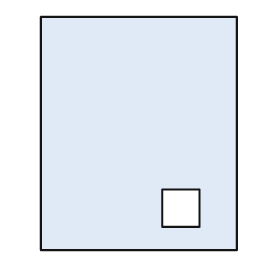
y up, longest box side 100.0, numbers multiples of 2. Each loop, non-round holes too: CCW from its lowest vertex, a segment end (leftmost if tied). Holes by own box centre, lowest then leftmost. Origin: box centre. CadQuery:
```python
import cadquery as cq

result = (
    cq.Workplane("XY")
    .moveTo(-42.0, -50.0)
    .lineTo(42.0, -50.0)
    .lineTo(42.0, 50.0)
    .lineTo(-42.0, 50.0)
    .close()
    .moveTo(10.0, -40.0)
    .lineTo(26.0, -40.0)
    .lineTo(26.0, -24.0)
    .lineTo(10.0, -24.0)
    .close()
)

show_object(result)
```